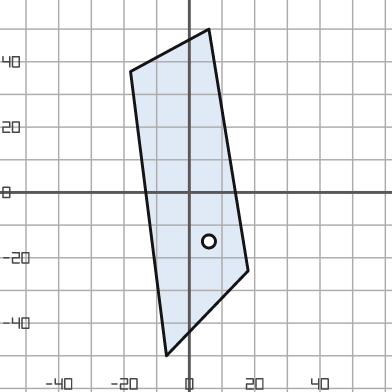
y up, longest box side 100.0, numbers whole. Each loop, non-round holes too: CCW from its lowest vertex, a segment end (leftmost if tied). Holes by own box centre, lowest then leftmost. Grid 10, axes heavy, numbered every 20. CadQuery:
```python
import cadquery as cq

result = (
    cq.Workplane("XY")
    .moveTo(-7.0, -50.0)
    .lineTo(18.0, -24.0)
    .lineTo(6.0, 50.0)
    .lineTo(-18.0, 37.0)
    .close()
    .moveTo(6.0, -15.0)
    .circle(2.0)
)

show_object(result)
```